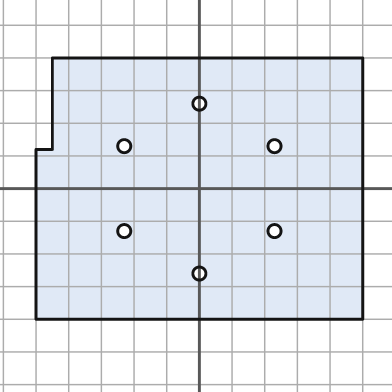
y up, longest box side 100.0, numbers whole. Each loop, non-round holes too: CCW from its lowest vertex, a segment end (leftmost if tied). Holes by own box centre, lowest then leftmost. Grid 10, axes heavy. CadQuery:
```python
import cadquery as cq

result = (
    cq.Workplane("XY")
    .moveTo(-50.0, -40.0)
    .lineTo(50.0, -40.0)
    .lineTo(50.0, 40.0)
    .lineTo(-45.0, 40.0)
    .lineTo(-45.0, 12.0)
    .lineTo(-50.0, 12.0)
    .close()
    .moveTo(0.0, -26.0)
    .circle(2.0)
    .moveTo(-23.0, -13.0)
    .circle(2.0)
    .moveTo(23.0, -13.0)
    .circle(2.0)
    .moveTo(-23.0, 13.0)
    .circle(2.0)
    .moveTo(23.0, 13.0)
    .circle(2.0)
    .moveTo(0.0, 26.0)
    .circle(2.0)
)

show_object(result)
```